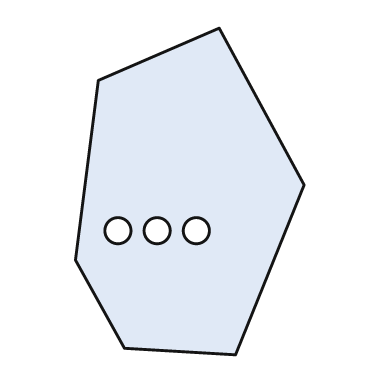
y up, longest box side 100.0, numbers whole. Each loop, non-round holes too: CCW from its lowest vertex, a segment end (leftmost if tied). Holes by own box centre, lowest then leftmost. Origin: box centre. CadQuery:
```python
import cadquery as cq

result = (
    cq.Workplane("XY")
    .moveTo(14.0, -50.0)
    .lineTo(35.0, 2.0)
    .lineTo(9.0, 50.0)
    .lineTo(-28.0, 34.0)
    .lineTo(-35.0, -21.0)
    .lineTo(-20.0, -48.0)
    .close()
    .moveTo(-22.0, -12.0)
    .circle(4.0)
    .moveTo(-10.0, -12.0)
    .circle(4.0)
    .moveTo(2.0, -12.0)
    .circle(4.0)
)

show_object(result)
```